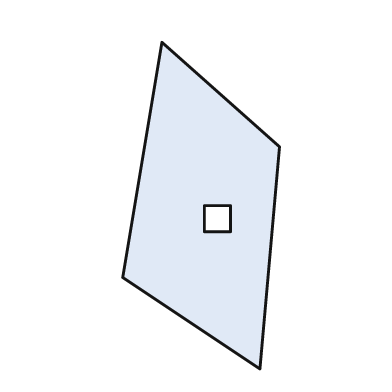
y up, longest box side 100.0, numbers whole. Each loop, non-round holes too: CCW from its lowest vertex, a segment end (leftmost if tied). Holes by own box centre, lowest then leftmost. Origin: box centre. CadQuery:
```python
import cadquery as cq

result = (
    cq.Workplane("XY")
    .moveTo(18.0, -50.0)
    .lineTo(24.0, 18.0)
    .lineTo(-12.0, 50.0)
    .lineTo(-24.0, -22.0)
    .close()
    .moveTo(1.0, -8.0)
    .lineTo(9.0, -8.0)
    .lineTo(9.0, 0.0)
    .lineTo(1.0, 0.0)
    .close()
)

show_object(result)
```